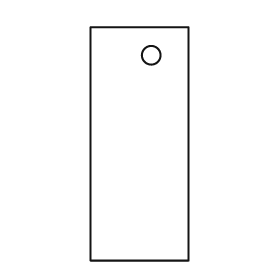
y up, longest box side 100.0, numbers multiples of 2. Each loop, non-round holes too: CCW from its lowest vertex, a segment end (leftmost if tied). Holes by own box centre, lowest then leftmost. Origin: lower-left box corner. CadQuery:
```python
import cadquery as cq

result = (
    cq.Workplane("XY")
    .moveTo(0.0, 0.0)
    .lineTo(42.0, 0.0)
    .lineTo(42.0, 100.0)
    .lineTo(0.0, 100.0)
    .close()
    .moveTo(26.0, 88.0)
    .circle(4.0)
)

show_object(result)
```